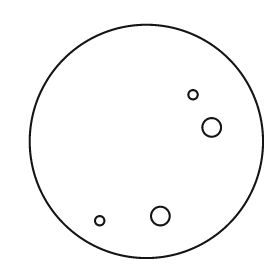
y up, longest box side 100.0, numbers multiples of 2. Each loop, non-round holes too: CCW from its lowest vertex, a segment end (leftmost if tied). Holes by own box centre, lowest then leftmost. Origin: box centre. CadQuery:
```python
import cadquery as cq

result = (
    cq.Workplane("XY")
    .moveTo(0.0, 0.0)
    .circle(50.0)
    .moveTo(-20.0, -34.0)
    .circle(2.0)
    .moveTo(6.0, -32.0)
    .circle(4.0)
    .moveTo(28.0, 6.0)
    .circle(4.0)
    .moveTo(20.0, 20.0)
    .circle(2.0)
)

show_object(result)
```